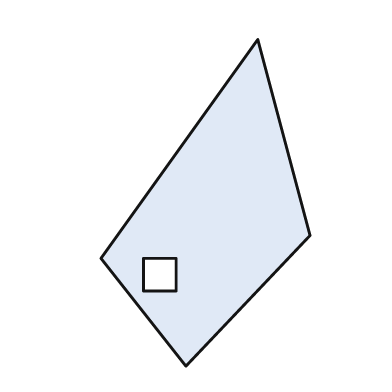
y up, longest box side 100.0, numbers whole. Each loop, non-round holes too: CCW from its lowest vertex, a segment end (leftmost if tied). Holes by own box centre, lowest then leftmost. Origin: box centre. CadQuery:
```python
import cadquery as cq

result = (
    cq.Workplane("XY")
    .moveTo(-6.0, -50.0)
    .lineTo(32.0, -10.0)
    .lineTo(16.0, 50.0)
    .lineTo(-32.0, -17.0)
    .close()
    .moveTo(-19.0, -27.0)
    .lineTo(-9.0, -27.0)
    .lineTo(-9.0, -17.0)
    .lineTo(-19.0, -17.0)
    .close()
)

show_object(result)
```